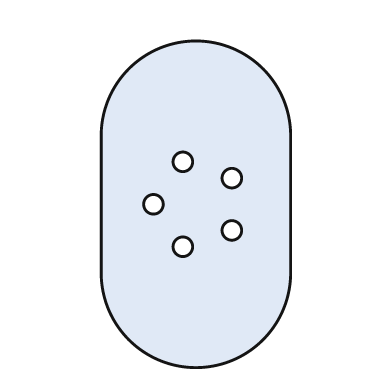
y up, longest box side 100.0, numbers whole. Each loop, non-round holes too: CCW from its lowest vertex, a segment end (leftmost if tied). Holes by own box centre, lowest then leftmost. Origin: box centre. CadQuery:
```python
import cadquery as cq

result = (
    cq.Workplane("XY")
    .moveTo(-29.0, -21.0)
    .threePointArc((0.0, -50.0), (29.0, -21.0))
    .lineTo(29.0, 21.0)
    .threePointArc((0.0, 50.0), (-29.0, 21.0))
    .close()
    .moveTo(-4.0, -13.0)
    .circle(3.0)
    .moveTo(11.0, -8.0)
    .circle(3.0)
    .moveTo(-13.0, 0.0)
    .circle(3.0)
    .moveTo(11.0, 8.0)
    .circle(3.0)
    .moveTo(-4.0, 13.0)
    .circle(3.0)
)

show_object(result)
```